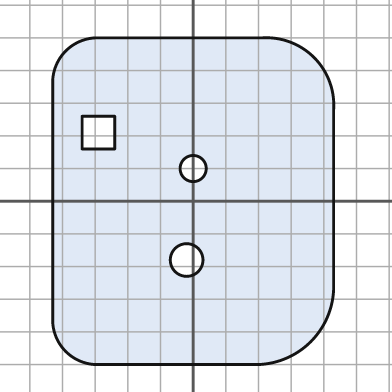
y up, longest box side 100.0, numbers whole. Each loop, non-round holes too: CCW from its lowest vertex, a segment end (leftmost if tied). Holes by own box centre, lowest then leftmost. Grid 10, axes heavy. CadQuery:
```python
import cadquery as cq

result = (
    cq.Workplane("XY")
    .moveTo(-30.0, -50.0)
    .lineTo(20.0, -50.0)
    .threePointArc((36.0, -43.0), (43.0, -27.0))
    .lineTo(43.0, 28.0)
    .threePointArc((37.0, 44.0), (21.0, 50.0))
    .lineTo(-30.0, 50.0)
    .threePointArc((-39.0, 46.0), (-43.0, 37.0))
    .lineTo(-43.0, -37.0)
    .threePointArc((-39.0, -46.0), (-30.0, -50.0))
    .close()
    .moveTo(-2.0, -18.0)
    .circle(5.0)
    .moveTo(0.0, 10.0)
    .circle(4.0)
    .moveTo(-34.0, 16.0)
    .lineTo(-24.0, 16.0)
    .lineTo(-24.0, 26.0)
    .lineTo(-34.0, 26.0)
    .close()
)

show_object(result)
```